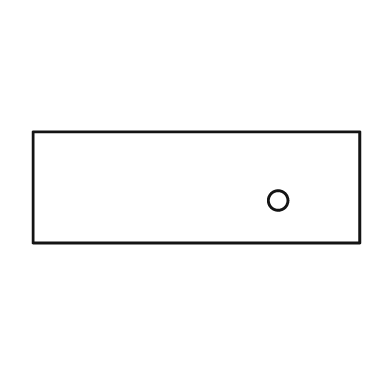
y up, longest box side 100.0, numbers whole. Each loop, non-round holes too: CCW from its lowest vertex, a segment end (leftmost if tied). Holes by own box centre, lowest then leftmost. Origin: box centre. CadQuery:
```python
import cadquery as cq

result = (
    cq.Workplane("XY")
    .moveTo(-50.0, -17.0)
    .lineTo(50.0, -17.0)
    .lineTo(50.0, 17.0)
    .lineTo(-50.0, 17.0)
    .close()
    .moveTo(25.0, -4.0)
    .circle(3.0)
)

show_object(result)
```